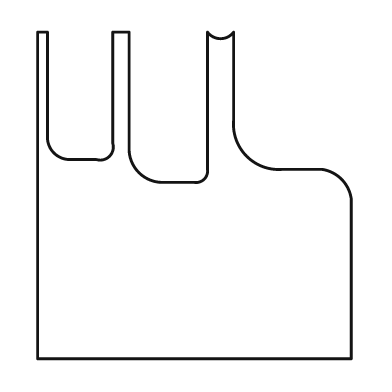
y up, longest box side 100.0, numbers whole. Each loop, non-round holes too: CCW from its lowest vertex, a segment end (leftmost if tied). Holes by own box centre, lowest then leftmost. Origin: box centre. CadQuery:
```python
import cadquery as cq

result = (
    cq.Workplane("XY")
    .moveTo(-48.0, -50.0)
    .lineTo(48.0, -50.0)
    .lineTo(48.0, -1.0)
    .threePointArc((45.0, 5.0), (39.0, 8.0))
    .lineTo(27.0, 8.0)
    .threePointArc((16.0, 12.0), (12.0, 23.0))
    .lineTo(12.0, 50.0)
    .threePointArc((8.0, 48.0), (4.0, 50.0))
    .lineTo(4.0, 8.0)
    .threePointArc((3.0, 5.0), (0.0, 4.0))
    .lineTo(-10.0, 4.0)
    .threePointArc((-17.0, 7.0), (-20.0, 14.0))
    .lineTo(-20.0, 50.0)
    .lineTo(-25.0, 50.0)
    .lineTo(-25.0, 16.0)
    .threePointArc((-26.0, 12.0), (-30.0, 11.0))
    .lineTo(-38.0, 11.0)
    .threePointArc((-43.0, 13.0), (-45.0, 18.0))
    .lineTo(-45.0, 50.0)
    .lineTo(-48.0, 50.0)
    .close()
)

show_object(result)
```